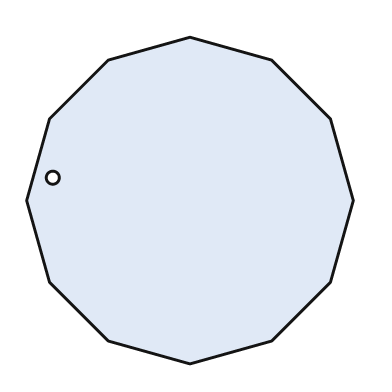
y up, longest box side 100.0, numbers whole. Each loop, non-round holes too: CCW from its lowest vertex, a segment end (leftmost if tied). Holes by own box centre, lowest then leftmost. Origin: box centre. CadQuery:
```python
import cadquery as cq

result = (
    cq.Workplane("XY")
    .moveTo(0.0, -50.0)
    .lineTo(25.0, -43.0)
    .lineTo(43.0, -25.0)
    .lineTo(50.0, 0.0)
    .lineTo(43.0, 25.0)
    .lineTo(25.0, 43.0)
    .lineTo(0.0, 50.0)
    .lineTo(-25.0, 43.0)
    .lineTo(-43.0, 25.0)
    .lineTo(-50.0, 0.0)
    .lineTo(-43.0, -25.0)
    .lineTo(-25.0, -43.0)
    .close()
    .moveTo(-42.0, 7.0)
    .circle(2.0)
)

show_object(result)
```